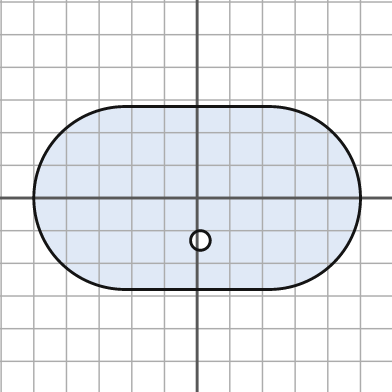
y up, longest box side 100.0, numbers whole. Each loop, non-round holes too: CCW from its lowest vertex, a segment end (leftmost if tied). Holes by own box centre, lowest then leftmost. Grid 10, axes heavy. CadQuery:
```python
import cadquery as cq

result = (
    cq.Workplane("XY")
    .moveTo(-22.0, -28.0)
    .lineTo(22.0, -28.0)
    .threePointArc((50.0, 0.0), (22.0, 28.0))
    .lineTo(-22.0, 28.0)
    .threePointArc((-50.0, 0.0), (-22.0, -28.0))
    .close()
    .moveTo(1.0, -13.0)
    .circle(3.0)
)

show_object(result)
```